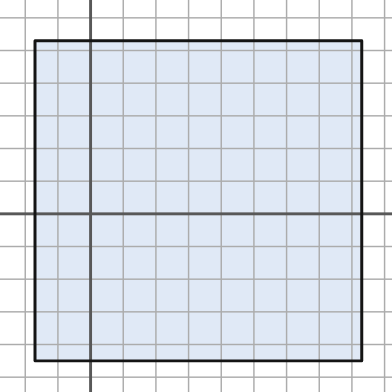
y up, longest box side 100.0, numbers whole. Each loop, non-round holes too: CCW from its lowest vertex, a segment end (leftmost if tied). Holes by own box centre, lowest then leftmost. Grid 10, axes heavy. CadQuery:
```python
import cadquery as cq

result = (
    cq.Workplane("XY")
    .moveTo(-17.0, -45.0)
    .lineTo(83.0, -45.0)
    .lineTo(83.0, 53.0)
    .lineTo(-17.0, 53.0)
    .close()
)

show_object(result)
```